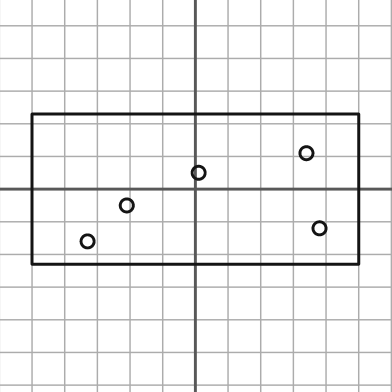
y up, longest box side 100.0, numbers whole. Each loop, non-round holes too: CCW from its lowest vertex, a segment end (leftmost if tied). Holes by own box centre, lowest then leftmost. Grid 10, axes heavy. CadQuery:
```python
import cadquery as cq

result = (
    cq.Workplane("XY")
    .moveTo(-50.0, -23.0)
    .lineTo(50.0, -23.0)
    .lineTo(50.0, 23.0)
    .lineTo(-50.0, 23.0)
    .close()
    .moveTo(-33.0, -16.0)
    .circle(2.0)
    .moveTo(38.0, -12.0)
    .circle(2.0)
    .moveTo(-21.0, -5.0)
    .circle(2.0)
    .moveTo(1.0, 5.0)
    .circle(2.0)
    .moveTo(34.0, 11.0)
    .circle(2.0)
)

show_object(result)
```